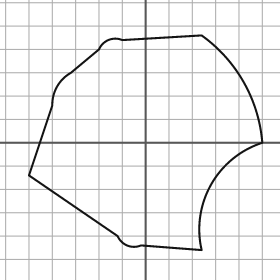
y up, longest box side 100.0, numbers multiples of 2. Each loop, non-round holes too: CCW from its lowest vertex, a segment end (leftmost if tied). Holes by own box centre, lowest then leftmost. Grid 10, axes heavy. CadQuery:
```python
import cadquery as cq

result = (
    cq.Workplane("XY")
    .moveTo(24.0, -46.0)
    .threePointArc((28.0, -18.0), (50.0, 0.0))
    .threePointArc((42.0, 26.0), (24.0, 46.0))
    .lineTo(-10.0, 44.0)
    .threePointArc((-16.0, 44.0), (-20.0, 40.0))
    .lineTo(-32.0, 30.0)
    .threePointArc((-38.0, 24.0), (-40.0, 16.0))
    .lineTo(-50.0, -14.0)
    .lineTo(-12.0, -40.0)
    .threePointArc((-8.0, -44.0), (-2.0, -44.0))
    .close()
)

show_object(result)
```